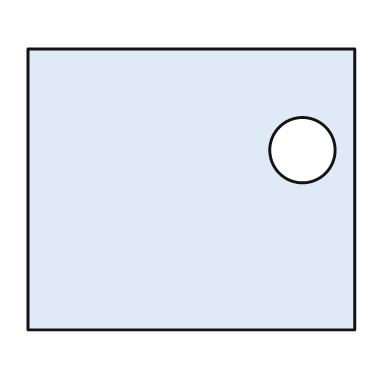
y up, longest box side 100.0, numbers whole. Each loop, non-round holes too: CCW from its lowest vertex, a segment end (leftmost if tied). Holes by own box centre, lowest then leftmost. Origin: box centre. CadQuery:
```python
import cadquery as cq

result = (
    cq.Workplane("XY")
    .moveTo(-50.0, -43.0)
    .lineTo(50.0, -43.0)
    .lineTo(50.0, 43.0)
    .lineTo(-50.0, 43.0)
    .close()
    .moveTo(34.0, 12.0)
    .circle(10.0)
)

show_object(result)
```